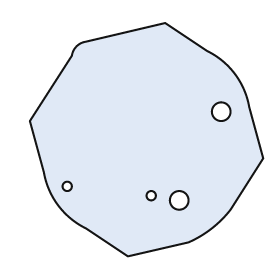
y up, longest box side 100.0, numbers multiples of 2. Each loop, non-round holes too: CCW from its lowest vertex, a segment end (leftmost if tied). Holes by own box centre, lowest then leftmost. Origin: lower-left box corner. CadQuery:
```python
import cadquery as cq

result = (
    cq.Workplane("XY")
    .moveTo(42.0, 0.0)
    .lineTo(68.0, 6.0)
    .threePointArc((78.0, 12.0), (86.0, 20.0))
    .lineTo(100.0, 42.0)
    .lineTo(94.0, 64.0)
    .threePointArc((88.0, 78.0), (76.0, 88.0))
    .lineTo(58.0, 100.0)
    .lineTo(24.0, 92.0)
    .threePointArc((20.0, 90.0), (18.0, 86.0))
    .lineTo(0.0, 58.0)
    .lineTo(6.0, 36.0)
    .threePointArc((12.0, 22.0), (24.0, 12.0))
    .close()
    .moveTo(64.0, 24.0)
    .circle(4.0)
    .moveTo(52.0, 26.0)
    .circle(2.0)
    .moveTo(16.0, 30.0)
    .circle(2.0)
    .moveTo(82.0, 62.0)
    .circle(4.0)
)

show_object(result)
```